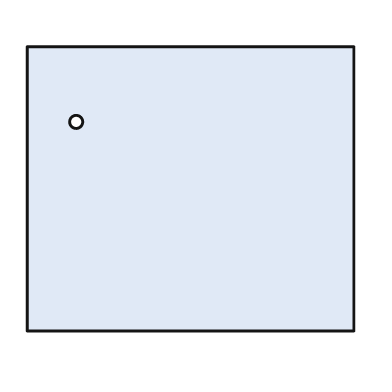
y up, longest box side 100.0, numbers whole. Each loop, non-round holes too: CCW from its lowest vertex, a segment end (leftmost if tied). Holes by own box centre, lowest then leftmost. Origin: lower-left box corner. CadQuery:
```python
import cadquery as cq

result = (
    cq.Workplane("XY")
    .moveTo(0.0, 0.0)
    .lineTo(100.0, 0.0)
    .lineTo(100.0, 87.0)
    .lineTo(0.0, 87.0)
    .close()
    .moveTo(15.0, 64.0)
    .circle(2.0)
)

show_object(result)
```